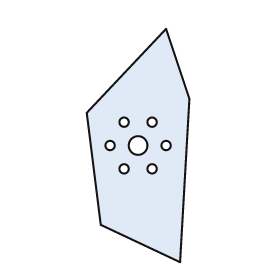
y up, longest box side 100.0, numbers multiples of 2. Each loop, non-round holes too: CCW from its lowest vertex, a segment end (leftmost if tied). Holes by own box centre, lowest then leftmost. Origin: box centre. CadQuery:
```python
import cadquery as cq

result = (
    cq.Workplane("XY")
    .moveTo(18.0, -50.0)
    .lineTo(22.0, 20.0)
    .lineTo(12.0, 50.0)
    .lineTo(-22.0, 14.0)
    .lineTo(-16.0, -34.0)
    .close()
    .moveTo(-6.0, -10.0)
    .circle(2.0)
    .moveTo(6.0, -10.0)
    .circle(2.0)
    .moveTo(-12.0, 0.0)
    .circle(2.0)
    .moveTo(0.0, 0.0)
    .circle(4.0)
    .moveTo(12.0, 0.0)
    .circle(2.0)
    .moveTo(-6.0, 10.0)
    .circle(2.0)
    .moveTo(6.0, 10.0)
    .circle(2.0)
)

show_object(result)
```